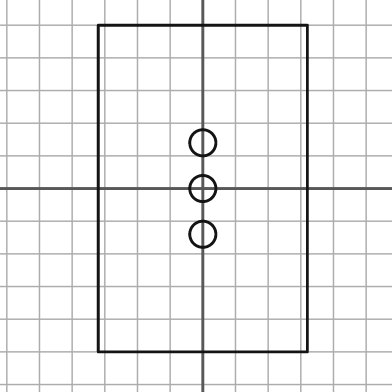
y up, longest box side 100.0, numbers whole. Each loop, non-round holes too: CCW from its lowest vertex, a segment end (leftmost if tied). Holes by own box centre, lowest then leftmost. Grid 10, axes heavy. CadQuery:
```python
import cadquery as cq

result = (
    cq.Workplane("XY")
    .moveTo(-32.0, -50.0)
    .lineTo(32.0, -50.0)
    .lineTo(32.0, 50.0)
    .lineTo(-32.0, 50.0)
    .close()
    .moveTo(0.0, -14.0)
    .circle(4.0)
    .moveTo(0.0, 0.0)
    .circle(4.0)
    .moveTo(0.0, 14.0)
    .circle(4.0)
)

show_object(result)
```